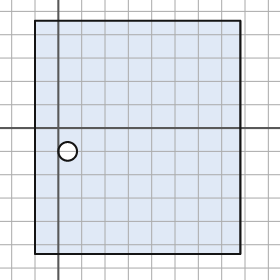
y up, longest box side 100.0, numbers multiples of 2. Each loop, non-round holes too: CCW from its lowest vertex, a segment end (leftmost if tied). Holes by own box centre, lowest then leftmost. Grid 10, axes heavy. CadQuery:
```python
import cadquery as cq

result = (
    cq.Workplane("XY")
    .moveTo(-10.0, -54.0)
    .lineTo(78.0, -54.0)
    .lineTo(78.0, 46.0)
    .lineTo(-10.0, 46.0)
    .close()
    .moveTo(4.0, -10.0)
    .circle(4.0)
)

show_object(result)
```